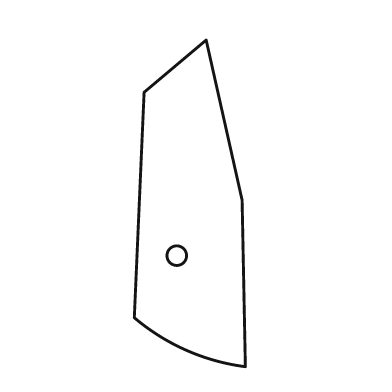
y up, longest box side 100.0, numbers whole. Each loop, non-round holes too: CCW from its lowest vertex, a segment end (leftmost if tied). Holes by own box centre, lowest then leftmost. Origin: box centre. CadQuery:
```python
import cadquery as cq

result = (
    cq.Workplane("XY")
    .moveTo(17.0, -50.0)
    .lineTo(16.0, 1.0)
    .lineTo(5.0, 50.0)
    .lineTo(-14.0, 34.0)
    .lineTo(-17.0, -35.0)
    .threePointArc((-1.0, -45.0), (17.0, -50.0))
    .close()
    .moveTo(-4.0, -16.0)
    .circle(3.0)
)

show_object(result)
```